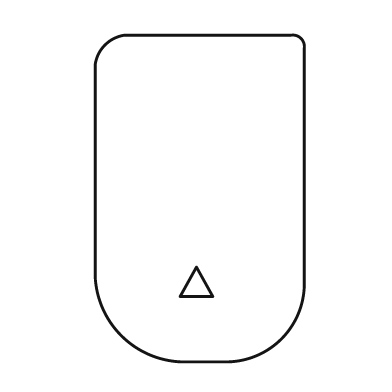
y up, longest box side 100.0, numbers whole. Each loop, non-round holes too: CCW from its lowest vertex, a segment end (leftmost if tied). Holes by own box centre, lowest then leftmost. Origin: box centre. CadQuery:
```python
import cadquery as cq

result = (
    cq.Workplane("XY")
    .moveTo(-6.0, -50.0)
    .lineTo(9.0, -50.0)
    .threePointArc((25.0, -43.0), (32.0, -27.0))
    .lineTo(32.0, 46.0)
    .threePointArc((31.0, 49.0), (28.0, 50.0))
    .lineTo(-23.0, 50.0)
    .threePointArc((-29.0, 47.0), (-32.0, 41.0))
    .lineTo(-32.0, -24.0)
    .threePointArc((-24.0, -42.0), (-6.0, -50.0))
    .close()
    .moveTo(-6.0, -30.0)
    .lineTo(4.0, -30.0)
    .lineTo(-1.0, -21.0)
    .close()
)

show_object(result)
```